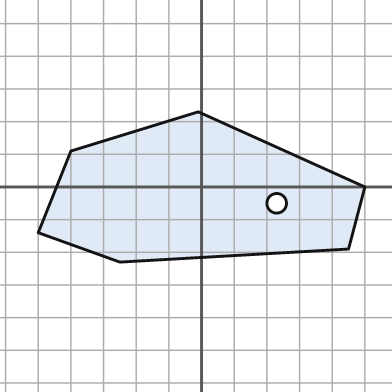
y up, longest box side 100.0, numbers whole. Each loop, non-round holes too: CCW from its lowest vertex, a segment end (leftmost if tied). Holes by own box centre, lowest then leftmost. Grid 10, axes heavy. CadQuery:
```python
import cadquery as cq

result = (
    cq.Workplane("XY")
    .moveTo(-25.0, -23.0)
    .lineTo(45.0, -19.0)
    .lineTo(50.0, 0.0)
    .lineTo(-1.0, 23.0)
    .lineTo(-40.0, 11.0)
    .lineTo(-50.0, -14.0)
    .close()
    .moveTo(23.0, -5.0)
    .circle(3.0)
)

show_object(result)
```